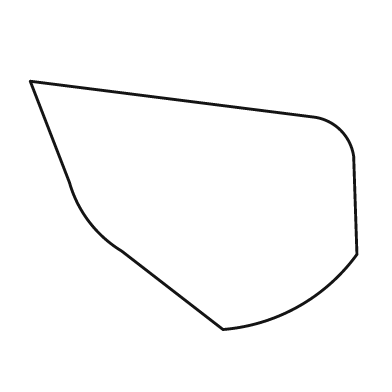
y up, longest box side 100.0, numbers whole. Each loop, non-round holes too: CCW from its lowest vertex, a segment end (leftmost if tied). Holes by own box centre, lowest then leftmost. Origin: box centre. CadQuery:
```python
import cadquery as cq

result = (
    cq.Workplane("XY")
    .moveTo(9.0, -38.0)
    .threePointArc((32.0, -31.0), (50.0, -15.0))
    .lineTo(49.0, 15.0)
    .threePointArc((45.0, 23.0), (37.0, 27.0))
    .lineTo(-50.0, 38.0)
    .lineTo(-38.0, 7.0)
    .threePointArc((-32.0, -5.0), (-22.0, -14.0))
    .close()
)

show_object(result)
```